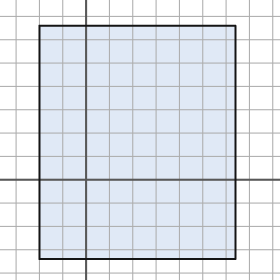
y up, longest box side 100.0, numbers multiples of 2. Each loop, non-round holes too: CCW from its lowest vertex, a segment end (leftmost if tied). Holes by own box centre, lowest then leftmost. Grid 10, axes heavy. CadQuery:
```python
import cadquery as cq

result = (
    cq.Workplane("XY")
    .moveTo(-20.0, -34.0)
    .lineTo(64.0, -34.0)
    .lineTo(64.0, 66.0)
    .lineTo(-20.0, 66.0)
    .close()
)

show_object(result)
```